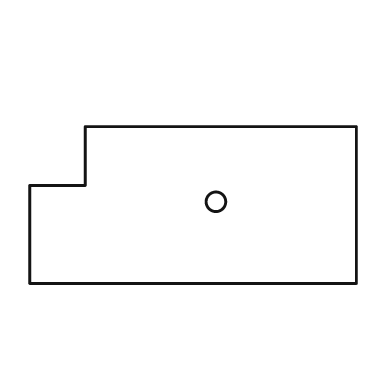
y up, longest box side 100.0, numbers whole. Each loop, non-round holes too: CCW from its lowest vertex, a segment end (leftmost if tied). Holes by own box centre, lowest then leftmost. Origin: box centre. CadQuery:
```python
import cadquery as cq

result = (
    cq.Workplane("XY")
    .moveTo(-50.0, -24.0)
    .lineTo(50.0, -24.0)
    .lineTo(50.0, 24.0)
    .lineTo(-33.0, 24.0)
    .lineTo(-33.0, 6.0)
    .lineTo(-50.0, 6.0)
    .close()
    .moveTo(7.0, 1.0)
    .circle(3.0)
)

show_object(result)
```